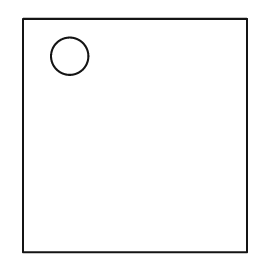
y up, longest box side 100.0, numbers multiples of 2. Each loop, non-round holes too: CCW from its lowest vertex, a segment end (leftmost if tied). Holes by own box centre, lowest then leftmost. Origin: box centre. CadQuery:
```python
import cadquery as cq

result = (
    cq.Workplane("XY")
    .moveTo(-48.0, -50.0)
    .lineTo(48.0, -50.0)
    .lineTo(48.0, 50.0)
    .lineTo(-48.0, 50.0)
    .close()
    .moveTo(-28.0, 34.0)
    .circle(8.0)
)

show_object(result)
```